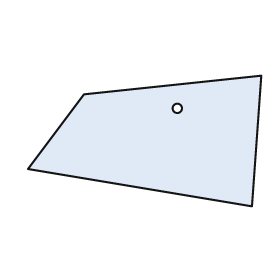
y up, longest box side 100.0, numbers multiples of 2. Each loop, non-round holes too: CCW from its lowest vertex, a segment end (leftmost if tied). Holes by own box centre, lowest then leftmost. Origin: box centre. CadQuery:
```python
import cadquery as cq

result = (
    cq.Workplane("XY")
    .moveTo(46.0, -28.0)
    .lineTo(50.0, 28.0)
    .lineTo(-26.0, 20.0)
    .lineTo(-50.0, -12.0)
    .close()
    .moveTo(14.0, 14.0)
    .circle(2.0)
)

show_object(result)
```